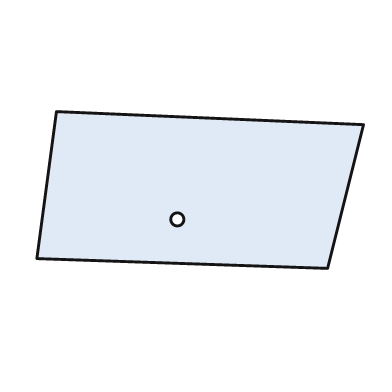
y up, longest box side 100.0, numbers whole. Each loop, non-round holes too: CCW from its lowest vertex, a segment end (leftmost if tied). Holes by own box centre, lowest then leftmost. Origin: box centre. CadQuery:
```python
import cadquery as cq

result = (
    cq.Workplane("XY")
    .moveTo(39.0, -24.0)
    .lineTo(50.0, 20.0)
    .lineTo(-44.0, 24.0)
    .lineTo(-50.0, -21.0)
    .close()
    .moveTo(-7.0, -9.0)
    .circle(2.0)
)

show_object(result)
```